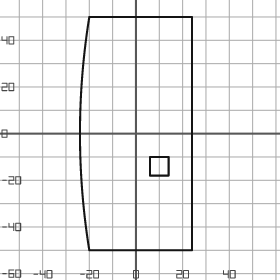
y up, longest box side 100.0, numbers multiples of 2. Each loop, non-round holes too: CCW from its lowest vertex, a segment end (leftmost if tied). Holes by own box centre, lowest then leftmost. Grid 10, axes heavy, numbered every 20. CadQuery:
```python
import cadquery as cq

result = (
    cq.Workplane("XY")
    .moveTo(-20.0, -50.0)
    .lineTo(24.0, -50.0)
    .lineTo(24.0, 50.0)
    .lineTo(-20.0, 50.0)
    .threePointArc((-24.0, 0.0), (-20.0, -50.0))
    .close()
    .moveTo(6.0, -18.0)
    .lineTo(14.0, -18.0)
    .lineTo(14.0, -10.0)
    .lineTo(6.0, -10.0)
    .close()
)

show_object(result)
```